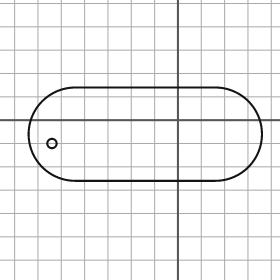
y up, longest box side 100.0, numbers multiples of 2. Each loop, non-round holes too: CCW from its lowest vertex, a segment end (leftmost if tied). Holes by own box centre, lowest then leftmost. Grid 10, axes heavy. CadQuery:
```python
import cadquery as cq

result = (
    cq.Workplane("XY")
    .moveTo(-44.0, -26.0)
    .lineTo(16.0, -26.0)
    .threePointArc((36.0, -6.0), (16.0, 14.0))
    .lineTo(-44.0, 14.0)
    .threePointArc((-64.0, -6.0), (-44.0, -26.0))
    .close()
    .moveTo(-54.0, -10.0)
    .circle(2.0)
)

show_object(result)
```